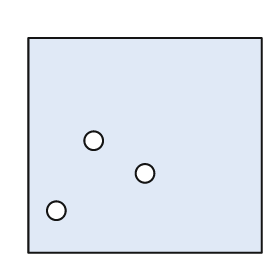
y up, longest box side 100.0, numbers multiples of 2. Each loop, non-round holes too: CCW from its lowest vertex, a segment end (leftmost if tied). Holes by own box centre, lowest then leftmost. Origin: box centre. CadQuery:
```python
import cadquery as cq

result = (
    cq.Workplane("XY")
    .moveTo(-50.0, -46.0)
    .lineTo(50.0, -46.0)
    .lineTo(50.0, 46.0)
    .lineTo(-50.0, 46.0)
    .close()
    .moveTo(-38.0, -28.0)
    .circle(4.0)
    .moveTo(0.0, -12.0)
    .circle(4.0)
    .moveTo(-22.0, 2.0)
    .circle(4.0)
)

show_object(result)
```